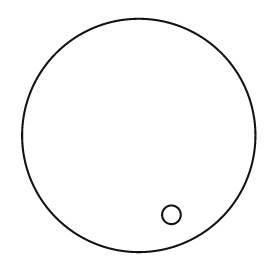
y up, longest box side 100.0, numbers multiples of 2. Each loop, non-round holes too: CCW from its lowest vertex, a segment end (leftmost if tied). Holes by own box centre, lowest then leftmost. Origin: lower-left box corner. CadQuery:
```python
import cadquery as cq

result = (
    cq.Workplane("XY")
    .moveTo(50.0, 50.0)
    .circle(50.0)
    .moveTo(64.0, 16.0)
    .circle(4.0)
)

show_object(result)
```